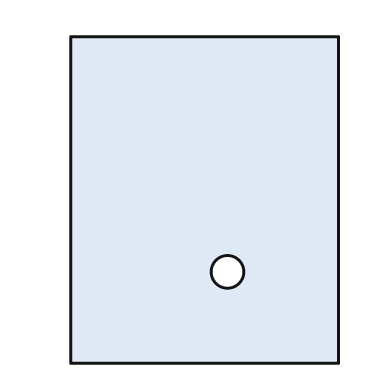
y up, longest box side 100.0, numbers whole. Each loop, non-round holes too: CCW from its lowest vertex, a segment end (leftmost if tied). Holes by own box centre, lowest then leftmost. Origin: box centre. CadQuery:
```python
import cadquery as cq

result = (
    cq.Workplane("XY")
    .moveTo(-41.0, -50.0)
    .lineTo(41.0, -50.0)
    .lineTo(41.0, 50.0)
    .lineTo(-41.0, 50.0)
    .close()
    .moveTo(7.0, -22.0)
    .circle(5.0)
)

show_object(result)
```